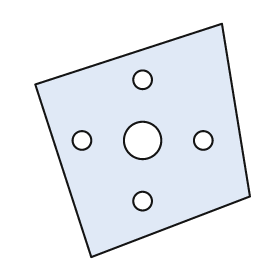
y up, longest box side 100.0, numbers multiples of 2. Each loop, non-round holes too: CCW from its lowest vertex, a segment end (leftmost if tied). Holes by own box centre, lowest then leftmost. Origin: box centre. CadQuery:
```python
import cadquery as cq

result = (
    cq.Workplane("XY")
    .moveTo(-22.0, -50.0)
    .lineTo(46.0, -24.0)
    .lineTo(34.0, 50.0)
    .lineTo(-46.0, 24.0)
    .close()
    .moveTo(0.0, -26.0)
    .circle(4.0)
    .moveTo(-26.0, 0.0)
    .circle(4.0)
    .moveTo(0.0, 0.0)
    .circle(8.0)
    .moveTo(26.0, 0.0)
    .circle(4.0)
    .moveTo(0.0, 26.0)
    .circle(4.0)
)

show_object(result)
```